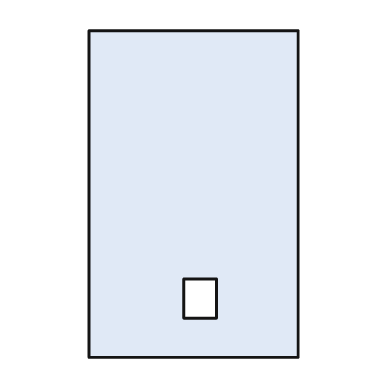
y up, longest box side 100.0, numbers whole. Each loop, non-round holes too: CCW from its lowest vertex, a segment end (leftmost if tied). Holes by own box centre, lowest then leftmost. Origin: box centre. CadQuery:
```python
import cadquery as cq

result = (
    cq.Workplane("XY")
    .moveTo(-32.0, -50.0)
    .lineTo(32.0, -50.0)
    .lineTo(32.0, 50.0)
    .lineTo(-32.0, 50.0)
    .close()
    .moveTo(-3.0, -38.0)
    .lineTo(7.0, -38.0)
    .lineTo(7.0, -26.0)
    .lineTo(-3.0, -26.0)
    .close()
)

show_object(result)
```